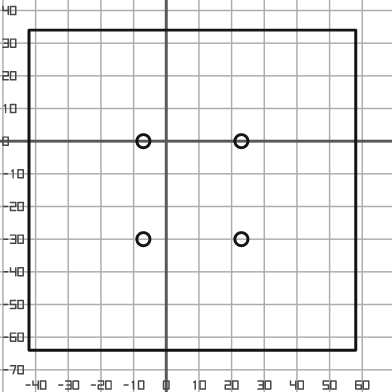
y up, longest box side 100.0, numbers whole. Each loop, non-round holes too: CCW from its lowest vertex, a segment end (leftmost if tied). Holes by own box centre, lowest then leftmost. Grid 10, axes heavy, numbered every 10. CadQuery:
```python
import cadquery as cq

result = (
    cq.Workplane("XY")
    .moveTo(-42.0, -64.0)
    .lineTo(58.0, -64.0)
    .lineTo(58.0, 34.0)
    .lineTo(-42.0, 34.0)
    .close()
    .moveTo(-7.0, -30.0)
    .circle(2.0)
    .moveTo(23.0, -30.0)
    .circle(2.0)
    .moveTo(-7.0, 0.0)
    .circle(2.0)
    .moveTo(23.0, 0.0)
    .circle(2.0)
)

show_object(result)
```